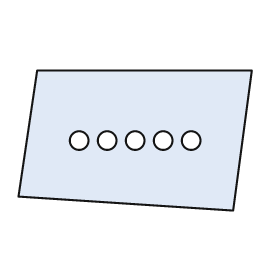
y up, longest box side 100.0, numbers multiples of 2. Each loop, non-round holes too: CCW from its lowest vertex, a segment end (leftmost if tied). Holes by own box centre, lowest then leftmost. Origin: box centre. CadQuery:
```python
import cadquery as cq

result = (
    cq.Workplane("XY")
    .moveTo(42.0, -30.0)
    .lineTo(50.0, 30.0)
    .lineTo(-42.0, 30.0)
    .lineTo(-50.0, -24.0)
    .close()
    .moveTo(-24.0, 0.0)
    .circle(4.0)
    .moveTo(-12.0, 0.0)
    .circle(4.0)
    .moveTo(0.0, 0.0)
    .circle(4.0)
    .moveTo(12.0, 0.0)
    .circle(4.0)
    .moveTo(24.0, 0.0)
    .circle(4.0)
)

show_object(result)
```